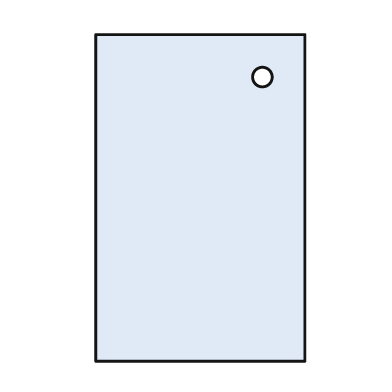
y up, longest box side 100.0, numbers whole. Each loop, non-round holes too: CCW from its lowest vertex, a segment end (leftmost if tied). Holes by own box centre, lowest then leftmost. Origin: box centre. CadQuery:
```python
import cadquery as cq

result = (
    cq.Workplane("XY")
    .moveTo(-32.0, -50.0)
    .lineTo(32.0, -50.0)
    .lineTo(32.0, 50.0)
    .lineTo(-32.0, 50.0)
    .close()
    .moveTo(19.0, 37.0)
    .circle(3.0)
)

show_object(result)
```